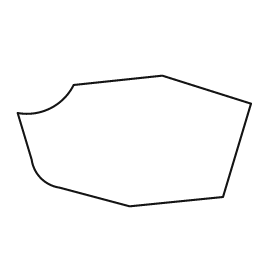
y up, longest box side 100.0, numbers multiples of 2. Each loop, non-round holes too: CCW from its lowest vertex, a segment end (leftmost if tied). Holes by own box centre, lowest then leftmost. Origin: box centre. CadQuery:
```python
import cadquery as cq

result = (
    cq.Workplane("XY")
    .moveTo(-2.0, -28.0)
    .lineTo(38.0, -24.0)
    .lineTo(50.0, 16.0)
    .lineTo(12.0, 28.0)
    .lineTo(-26.0, 24.0)
    .threePointArc((-36.0, 14.0), (-50.0, 12.0))
    .lineTo(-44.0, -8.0)
    .threePointArc((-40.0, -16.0), (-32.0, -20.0))
    .close()
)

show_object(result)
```